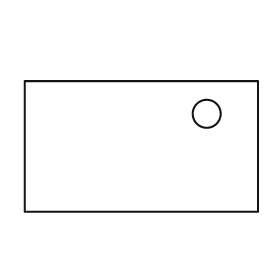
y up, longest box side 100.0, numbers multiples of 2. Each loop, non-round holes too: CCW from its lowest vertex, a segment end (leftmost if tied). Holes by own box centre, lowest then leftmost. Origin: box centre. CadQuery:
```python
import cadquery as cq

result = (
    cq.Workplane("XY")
    .moveTo(-50.0, -28.0)
    .lineTo(50.0, -28.0)
    .lineTo(50.0, 28.0)
    .lineTo(-50.0, 28.0)
    .close()
    .moveTo(28.0, 14.0)
    .circle(6.0)
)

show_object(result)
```